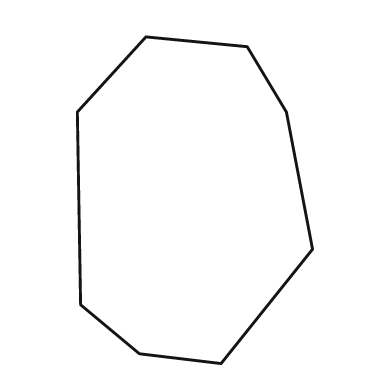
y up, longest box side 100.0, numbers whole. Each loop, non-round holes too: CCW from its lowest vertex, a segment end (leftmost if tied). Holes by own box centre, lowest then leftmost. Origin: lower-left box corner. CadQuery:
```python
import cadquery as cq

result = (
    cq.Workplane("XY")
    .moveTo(44.0, 0.0)
    .lineTo(72.0, 35.0)
    .lineTo(64.0, 77.0)
    .lineTo(52.0, 97.0)
    .lineTo(21.0, 100.0)
    .lineTo(0.0, 77.0)
    .lineTo(1.0, 18.0)
    .lineTo(19.0, 3.0)
    .close()
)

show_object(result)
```